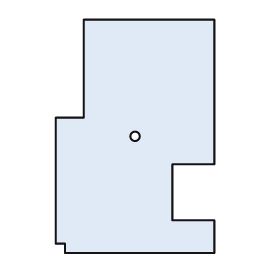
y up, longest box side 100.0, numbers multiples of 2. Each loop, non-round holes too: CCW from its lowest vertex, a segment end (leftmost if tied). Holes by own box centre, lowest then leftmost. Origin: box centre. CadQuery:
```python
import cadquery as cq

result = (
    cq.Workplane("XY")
    .moveTo(-30.0, -50.0)
    .lineTo(34.0, -50.0)
    .lineTo(34.0, -36.0)
    .lineTo(16.0, -36.0)
    .lineTo(16.0, -12.0)
    .lineTo(34.0, -12.0)
    .lineTo(34.0, 50.0)
    .lineTo(-22.0, 50.0)
    .lineTo(-22.0, 8.0)
    .lineTo(-34.0, 8.0)
    .lineTo(-34.0, -46.0)
    .lineTo(-30.0, -46.0)
    .close()
    .moveTo(0.0, 0.0)
    .circle(2.0)
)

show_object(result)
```